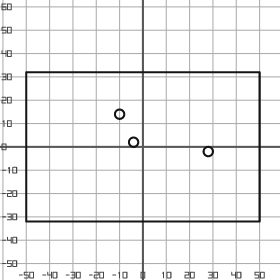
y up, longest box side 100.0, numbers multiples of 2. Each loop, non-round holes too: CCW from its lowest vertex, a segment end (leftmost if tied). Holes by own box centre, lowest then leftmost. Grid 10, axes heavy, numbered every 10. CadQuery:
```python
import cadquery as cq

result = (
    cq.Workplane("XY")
    .moveTo(-50.0, -32.0)
    .lineTo(50.0, -32.0)
    .lineTo(50.0, 32.0)
    .lineTo(-50.0, 32.0)
    .close()
    .moveTo(28.0, -2.0)
    .circle(2.0)
    .moveTo(-4.0, 2.0)
    .circle(2.0)
    .moveTo(-10.0, 14.0)
    .circle(2.0)
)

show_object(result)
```